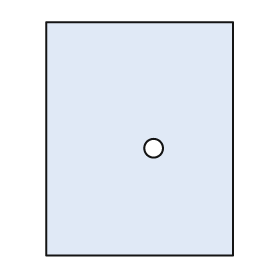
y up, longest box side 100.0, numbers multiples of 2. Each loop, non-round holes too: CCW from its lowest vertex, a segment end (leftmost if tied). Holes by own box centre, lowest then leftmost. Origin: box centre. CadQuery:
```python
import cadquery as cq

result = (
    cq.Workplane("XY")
    .moveTo(-40.0, -50.0)
    .lineTo(40.0, -50.0)
    .lineTo(40.0, 50.0)
    .lineTo(-40.0, 50.0)
    .close()
    .moveTo(6.0, -4.0)
    .circle(4.0)
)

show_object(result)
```